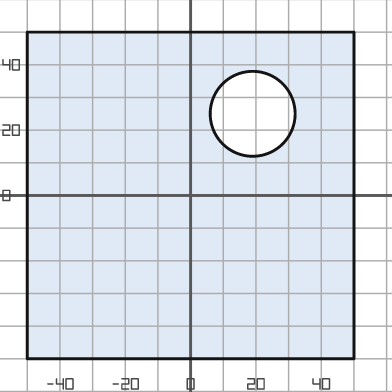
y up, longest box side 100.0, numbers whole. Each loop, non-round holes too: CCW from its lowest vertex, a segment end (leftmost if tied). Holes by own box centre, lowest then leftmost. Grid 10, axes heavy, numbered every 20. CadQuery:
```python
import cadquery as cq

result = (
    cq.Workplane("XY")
    .moveTo(-50.0, -50.0)
    .lineTo(50.0, -50.0)
    .lineTo(50.0, 50.0)
    .lineTo(-50.0, 50.0)
    .close()
    .moveTo(19.0, 25.0)
    .circle(13.0)
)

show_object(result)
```